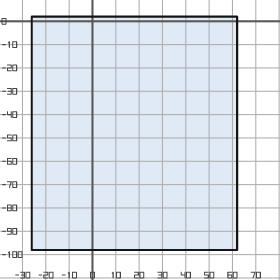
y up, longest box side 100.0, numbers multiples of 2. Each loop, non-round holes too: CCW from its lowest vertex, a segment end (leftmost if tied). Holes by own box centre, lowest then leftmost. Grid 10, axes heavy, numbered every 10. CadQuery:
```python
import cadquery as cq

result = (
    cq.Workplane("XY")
    .moveTo(-26.0, -98.0)
    .lineTo(62.0, -98.0)
    .lineTo(62.0, 2.0)
    .lineTo(-26.0, 2.0)
    .close()
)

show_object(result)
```